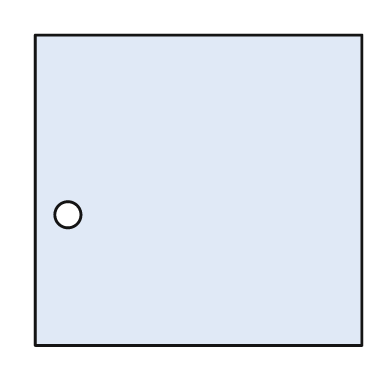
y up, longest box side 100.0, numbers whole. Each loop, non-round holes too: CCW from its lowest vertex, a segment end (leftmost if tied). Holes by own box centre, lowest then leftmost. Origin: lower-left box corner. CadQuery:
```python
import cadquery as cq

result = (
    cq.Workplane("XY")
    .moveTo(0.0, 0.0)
    .lineTo(100.0, 0.0)
    .lineTo(100.0, 95.0)
    .lineTo(0.0, 95.0)
    .close()
    .moveTo(10.0, 40.0)
    .circle(4.0)
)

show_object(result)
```